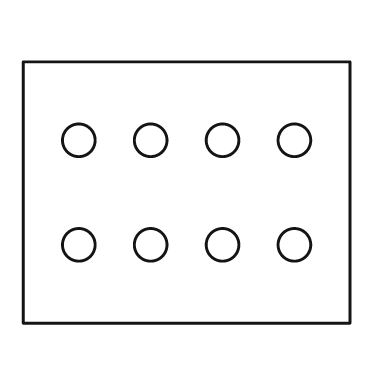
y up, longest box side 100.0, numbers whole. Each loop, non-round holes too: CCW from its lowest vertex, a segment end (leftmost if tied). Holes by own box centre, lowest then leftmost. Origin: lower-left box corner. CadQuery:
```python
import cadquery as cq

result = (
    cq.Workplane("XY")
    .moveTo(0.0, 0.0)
    .lineTo(100.0, 0.0)
    .lineTo(100.0, 80.0)
    .lineTo(0.0, 80.0)
    .close()
    .moveTo(17.0, 24.0)
    .circle(5.0)
    .moveTo(39.0, 24.0)
    .circle(5.0)
    .moveTo(61.0, 24.0)
    .circle(5.0)
    .moveTo(83.0, 24.0)
    .circle(5.0)
    .moveTo(17.0, 56.0)
    .circle(5.0)
    .moveTo(39.0, 56.0)
    .circle(5.0)
    .moveTo(61.0, 56.0)
    .circle(5.0)
    .moveTo(83.0, 56.0)
    .circle(5.0)
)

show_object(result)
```